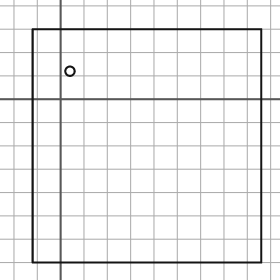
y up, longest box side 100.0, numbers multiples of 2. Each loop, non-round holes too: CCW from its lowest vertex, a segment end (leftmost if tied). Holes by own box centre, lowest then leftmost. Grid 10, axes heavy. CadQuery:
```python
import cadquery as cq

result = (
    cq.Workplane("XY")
    .moveTo(-12.0, -70.0)
    .lineTo(86.0, -70.0)
    .lineTo(86.0, 30.0)
    .lineTo(-12.0, 30.0)
    .close()
    .moveTo(4.0, 12.0)
    .circle(2.0)
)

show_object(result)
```